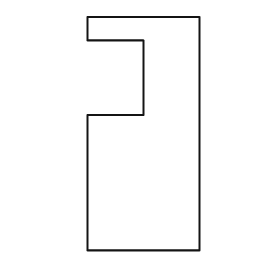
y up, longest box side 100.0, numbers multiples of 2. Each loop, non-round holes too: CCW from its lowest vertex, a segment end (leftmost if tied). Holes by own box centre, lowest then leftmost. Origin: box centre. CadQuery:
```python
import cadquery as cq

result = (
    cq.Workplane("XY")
    .moveTo(-24.0, -50.0)
    .lineTo(24.0, -50.0)
    .lineTo(24.0, 50.0)
    .lineTo(-24.0, 50.0)
    .lineTo(-24.0, 40.0)
    .lineTo(0.0, 40.0)
    .lineTo(0.0, 8.0)
    .lineTo(-24.0, 8.0)
    .close()
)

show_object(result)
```